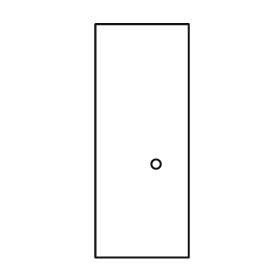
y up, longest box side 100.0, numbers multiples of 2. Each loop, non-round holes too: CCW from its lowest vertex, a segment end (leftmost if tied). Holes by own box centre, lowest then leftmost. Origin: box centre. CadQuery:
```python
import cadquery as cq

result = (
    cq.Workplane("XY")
    .moveTo(-20.0, -50.0)
    .lineTo(20.0, -50.0)
    .lineTo(20.0, 50.0)
    .lineTo(-20.0, 50.0)
    .close()
    .moveTo(6.0, -10.0)
    .circle(2.0)
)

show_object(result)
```